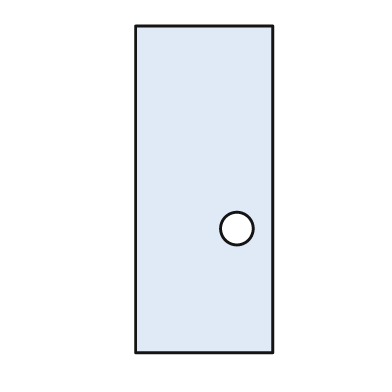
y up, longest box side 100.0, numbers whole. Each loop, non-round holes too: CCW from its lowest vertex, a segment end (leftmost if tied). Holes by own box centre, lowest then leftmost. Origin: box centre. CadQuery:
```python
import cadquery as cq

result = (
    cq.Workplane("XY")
    .moveTo(-21.0, -50.0)
    .lineTo(21.0, -50.0)
    .lineTo(21.0, 50.0)
    .lineTo(-21.0, 50.0)
    .close()
    .moveTo(10.0, -12.0)
    .circle(5.0)
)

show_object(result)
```